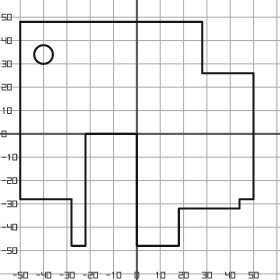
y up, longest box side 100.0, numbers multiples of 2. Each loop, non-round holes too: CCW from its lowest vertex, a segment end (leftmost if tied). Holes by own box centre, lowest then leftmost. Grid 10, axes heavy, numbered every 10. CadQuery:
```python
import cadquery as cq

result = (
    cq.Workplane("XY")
    .moveTo(-28.0, -48.0)
    .lineTo(-22.0, -48.0)
    .lineTo(-22.0, 0.0)
    .lineTo(0.0, 0.0)
    .lineTo(0.0, -48.0)
    .lineTo(18.0, -48.0)
    .lineTo(18.0, -32.0)
    .lineTo(44.0, -32.0)
    .lineTo(44.0, -28.0)
    .lineTo(50.0, -28.0)
    .lineTo(50.0, 26.0)
    .lineTo(28.0, 26.0)
    .lineTo(28.0, 48.0)
    .lineTo(-50.0, 48.0)
    .lineTo(-50.0, -28.0)
    .lineTo(-28.0, -28.0)
    .close()
    .moveTo(-40.0, 34.0)
    .circle(4.0)
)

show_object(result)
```